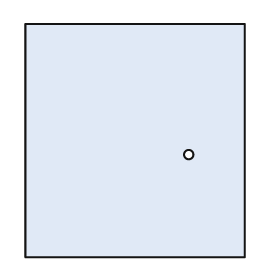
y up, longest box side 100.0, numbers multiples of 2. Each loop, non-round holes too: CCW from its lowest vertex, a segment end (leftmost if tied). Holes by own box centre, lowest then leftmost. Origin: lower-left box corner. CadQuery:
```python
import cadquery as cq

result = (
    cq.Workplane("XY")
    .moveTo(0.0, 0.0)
    .lineTo(94.0, 0.0)
    .lineTo(94.0, 100.0)
    .lineTo(0.0, 100.0)
    .close()
    .moveTo(70.0, 44.0)
    .circle(2.0)
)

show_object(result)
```